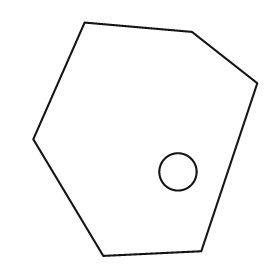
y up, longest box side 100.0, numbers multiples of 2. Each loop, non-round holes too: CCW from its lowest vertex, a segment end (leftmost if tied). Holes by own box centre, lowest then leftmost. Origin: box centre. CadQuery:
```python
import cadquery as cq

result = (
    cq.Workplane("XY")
    .moveTo(-18.0, -50.0)
    .lineTo(24.0, -48.0)
    .lineTo(48.0, 24.0)
    .lineTo(20.0, 46.0)
    .lineTo(-26.0, 50.0)
    .lineTo(-48.0, 0.0)
    .close()
    .moveTo(14.0, -14.0)
    .circle(8.0)
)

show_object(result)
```